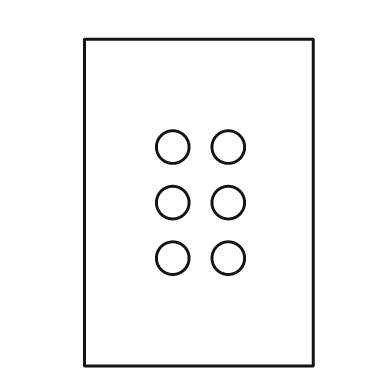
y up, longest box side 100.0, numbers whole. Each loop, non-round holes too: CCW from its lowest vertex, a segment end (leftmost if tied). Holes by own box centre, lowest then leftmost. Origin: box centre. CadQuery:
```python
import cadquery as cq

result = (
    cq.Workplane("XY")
    .moveTo(-35.0, -50.0)
    .lineTo(35.0, -50.0)
    .lineTo(35.0, 50.0)
    .lineTo(-35.0, 50.0)
    .close()
    .moveTo(-8.0, -17.0)
    .circle(5.0)
    .moveTo(9.0, -17.0)
    .circle(5.0)
    .moveTo(-8.0, 0.0)
    .circle(5.0)
    .moveTo(9.0, 0.0)
    .circle(5.0)
    .moveTo(-8.0, 17.0)
    .circle(5.0)
    .moveTo(9.0, 17.0)
    .circle(5.0)
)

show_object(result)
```